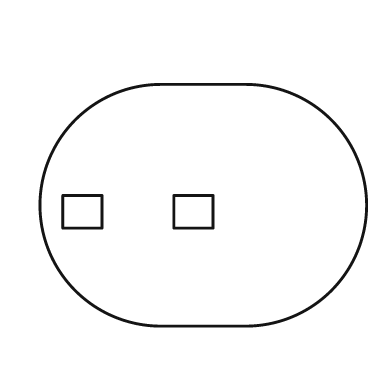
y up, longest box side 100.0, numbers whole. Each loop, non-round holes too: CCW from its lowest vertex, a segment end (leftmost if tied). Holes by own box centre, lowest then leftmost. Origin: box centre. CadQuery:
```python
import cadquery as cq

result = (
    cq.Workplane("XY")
    .moveTo(-13.0, -37.0)
    .lineTo(13.0, -37.0)
    .threePointArc((50.0, 0.0), (13.0, 37.0))
    .lineTo(-13.0, 37.0)
    .threePointArc((-50.0, 0.0), (-13.0, -37.0))
    .close()
    .moveTo(-43.0, -7.0)
    .lineTo(-31.0, -7.0)
    .lineTo(-31.0, 3.0)
    .lineTo(-43.0, 3.0)
    .close()
    .moveTo(-9.0, -7.0)
    .lineTo(3.0, -7.0)
    .lineTo(3.0, 3.0)
    .lineTo(-9.0, 3.0)
    .close()
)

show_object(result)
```